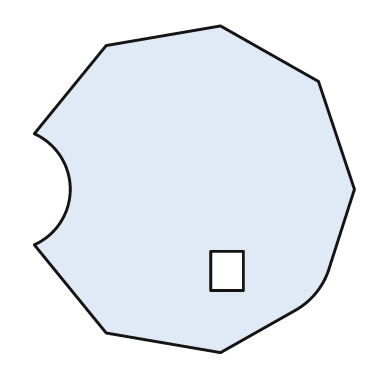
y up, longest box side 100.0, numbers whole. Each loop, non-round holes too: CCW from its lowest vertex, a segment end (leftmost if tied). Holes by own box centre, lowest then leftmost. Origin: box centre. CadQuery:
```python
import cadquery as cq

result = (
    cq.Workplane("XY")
    .moveTo(8.0, -50.0)
    .lineTo(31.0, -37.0)
    .threePointArc((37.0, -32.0), (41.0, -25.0))
    .lineTo(49.0, 0.0)
    .lineTo(38.0, 33.0)
    .lineTo(8.0, 50.0)
    .lineTo(-27.0, 44.0)
    .lineTo(-49.0, 17.0)
    .threePointArc((-38.0, 0.0), (-49.0, -17.0))
    .lineTo(-27.0, -44.0)
    .close()
    .moveTo(5.0, -31.0)
    .lineTo(15.0, -31.0)
    .lineTo(15.0, -19.0)
    .lineTo(5.0, -19.0)
    .close()
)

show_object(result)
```